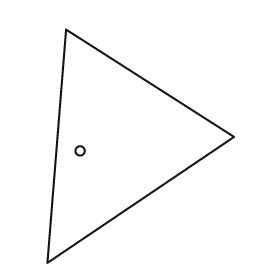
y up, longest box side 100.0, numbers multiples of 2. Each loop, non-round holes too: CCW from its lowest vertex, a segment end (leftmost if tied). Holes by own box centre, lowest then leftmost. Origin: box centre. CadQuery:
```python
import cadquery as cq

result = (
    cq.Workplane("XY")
    .moveTo(-40.0, -50.0)
    .lineTo(40.0, 4.0)
    .lineTo(-32.0, 50.0)
    .close()
    .moveTo(-26.0, -2.0)
    .circle(2.0)
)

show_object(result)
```